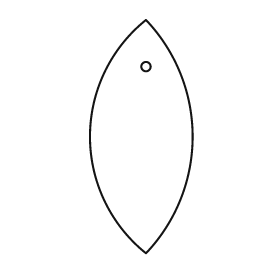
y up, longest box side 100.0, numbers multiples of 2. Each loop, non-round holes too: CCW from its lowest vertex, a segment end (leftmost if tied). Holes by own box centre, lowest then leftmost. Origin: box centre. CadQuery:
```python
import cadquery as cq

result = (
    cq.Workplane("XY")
    .moveTo(2.0, -50.0)
    .threePointArc((22.0, 0.0), (2.0, 50.0))
    .threePointArc((-22.0, 0.0), (2.0, -50.0))
    .close()
    .moveTo(2.0, 30.0)
    .circle(2.0)
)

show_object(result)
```